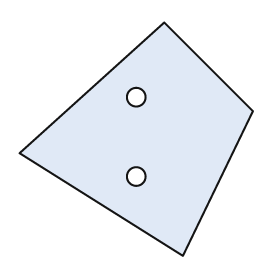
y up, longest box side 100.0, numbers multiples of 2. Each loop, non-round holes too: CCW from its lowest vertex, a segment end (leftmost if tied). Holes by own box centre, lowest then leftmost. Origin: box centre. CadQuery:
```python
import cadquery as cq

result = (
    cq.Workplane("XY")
    .moveTo(20.0, -50.0)
    .lineTo(50.0, 12.0)
    .lineTo(12.0, 50.0)
    .lineTo(-50.0, -6.0)
    .close()
    .moveTo(0.0, -16.0)
    .circle(4.0)
    .moveTo(0.0, 18.0)
    .circle(4.0)
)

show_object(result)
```